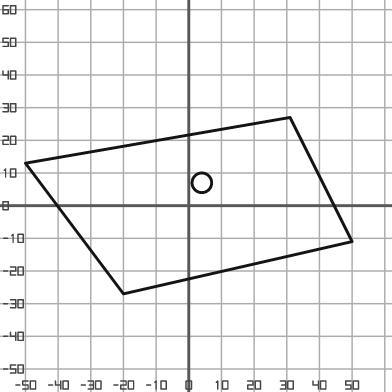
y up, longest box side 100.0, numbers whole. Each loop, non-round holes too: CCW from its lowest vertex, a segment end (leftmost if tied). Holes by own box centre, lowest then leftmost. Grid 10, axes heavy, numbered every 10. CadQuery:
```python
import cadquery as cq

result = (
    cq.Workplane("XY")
    .moveTo(-20.0, -27.0)
    .lineTo(50.0, -11.0)
    .lineTo(31.0, 27.0)
    .lineTo(-50.0, 13.0)
    .close()
    .moveTo(4.0, 7.0)
    .circle(3.0)
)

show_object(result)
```